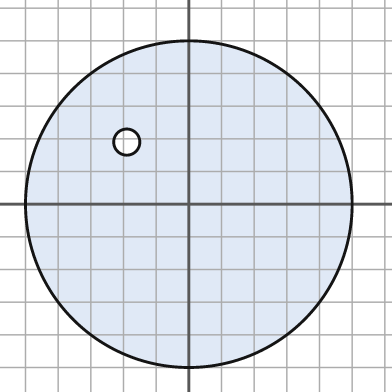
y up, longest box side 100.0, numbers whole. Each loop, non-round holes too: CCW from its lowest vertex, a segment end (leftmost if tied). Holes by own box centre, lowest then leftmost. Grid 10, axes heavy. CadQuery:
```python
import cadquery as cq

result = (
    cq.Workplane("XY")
    .moveTo(0.0, 0.0)
    .circle(50.0)
    .moveTo(-19.0, 19.0)
    .circle(4.0)
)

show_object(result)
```